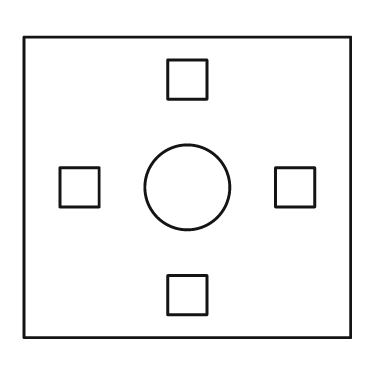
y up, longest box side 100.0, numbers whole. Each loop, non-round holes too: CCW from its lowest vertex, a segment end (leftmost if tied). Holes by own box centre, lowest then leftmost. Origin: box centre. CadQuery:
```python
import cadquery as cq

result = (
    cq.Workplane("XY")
    .moveTo(-50.0, -46.0)
    .lineTo(50.0, -46.0)
    .lineTo(50.0, 46.0)
    .lineTo(-50.0, 46.0)
    .close()
    .moveTo(-6.0, -39.0)
    .lineTo(6.0, -39.0)
    .lineTo(6.0, -27.0)
    .lineTo(-6.0, -27.0)
    .close()
    .moveTo(-39.0, -6.0)
    .lineTo(-27.0, -6.0)
    .lineTo(-27.0, 6.0)
    .lineTo(-39.0, 6.0)
    .close()
    .moveTo(0.0, 0.0)
    .circle(13.0)
    .moveTo(27.0, -6.0)
    .lineTo(39.0, -6.0)
    .lineTo(39.0, 6.0)
    .lineTo(27.0, 6.0)
    .close()
    .moveTo(-6.0, 27.0)
    .lineTo(6.0, 27.0)
    .lineTo(6.0, 39.0)
    .lineTo(-6.0, 39.0)
    .close()
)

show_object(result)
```